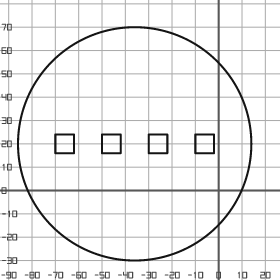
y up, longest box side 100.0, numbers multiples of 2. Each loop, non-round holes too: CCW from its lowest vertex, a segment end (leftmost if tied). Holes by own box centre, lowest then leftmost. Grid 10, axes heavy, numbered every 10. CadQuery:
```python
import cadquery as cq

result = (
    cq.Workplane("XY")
    .moveTo(-36.0, 20.0)
    .circle(50.0)
    .moveTo(-70.0, 16.0)
    .lineTo(-62.0, 16.0)
    .lineTo(-62.0, 24.0)
    .lineTo(-70.0, 24.0)
    .close()
    .moveTo(-50.0, 16.0)
    .lineTo(-42.0, 16.0)
    .lineTo(-42.0, 24.0)
    .lineTo(-50.0, 24.0)
    .close()
    .moveTo(-30.0, 16.0)
    .lineTo(-22.0, 16.0)
    .lineTo(-22.0, 24.0)
    .lineTo(-30.0, 24.0)
    .close()
    .moveTo(-10.0, 16.0)
    .lineTo(-2.0, 16.0)
    .lineTo(-2.0, 24.0)
    .lineTo(-10.0, 24.0)
    .close()
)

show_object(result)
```